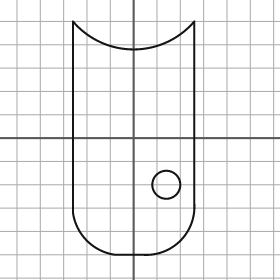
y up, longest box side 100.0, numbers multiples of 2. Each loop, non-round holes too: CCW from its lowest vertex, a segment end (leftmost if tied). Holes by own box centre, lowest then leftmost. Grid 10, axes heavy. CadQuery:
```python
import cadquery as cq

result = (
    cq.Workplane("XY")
    .moveTo(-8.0, -50.0)
    .lineTo(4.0, -50.0)
    .threePointArc((20.0, -44.0), (26.0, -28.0))
    .lineTo(26.0, 50.0)
    .threePointArc((0.0, 38.0), (-26.0, 50.0))
    .lineTo(-26.0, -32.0)
    .threePointArc((-20.0, -44.0), (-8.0, -50.0))
    .close()
    .moveTo(14.0, -20.0)
    .circle(6.0)
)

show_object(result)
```